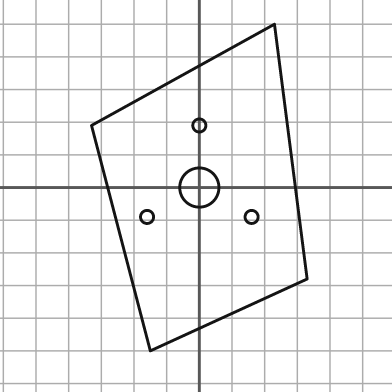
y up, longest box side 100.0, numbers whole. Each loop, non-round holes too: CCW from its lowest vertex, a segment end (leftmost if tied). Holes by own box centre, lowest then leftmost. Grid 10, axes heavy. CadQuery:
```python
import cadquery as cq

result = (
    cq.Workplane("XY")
    .moveTo(-15.0, -50.0)
    .lineTo(33.0, -28.0)
    .lineTo(23.0, 50.0)
    .lineTo(-33.0, 19.0)
    .close()
    .moveTo(-16.0, -9.0)
    .circle(2.0)
    .moveTo(16.0, -9.0)
    .circle(2.0)
    .moveTo(0.0, 0.0)
    .circle(6.0)
    .moveTo(0.0, 19.0)
    .circle(2.0)
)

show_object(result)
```